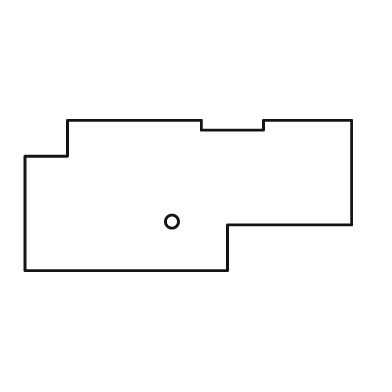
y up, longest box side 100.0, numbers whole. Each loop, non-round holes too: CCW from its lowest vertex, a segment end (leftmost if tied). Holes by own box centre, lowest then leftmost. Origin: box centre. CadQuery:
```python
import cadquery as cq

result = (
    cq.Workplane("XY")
    .moveTo(-50.0, -23.0)
    .lineTo(12.0, -23.0)
    .lineTo(12.0, -9.0)
    .lineTo(50.0, -9.0)
    .lineTo(50.0, 23.0)
    .lineTo(23.0, 23.0)
    .lineTo(23.0, 20.0)
    .lineTo(4.0, 20.0)
    .lineTo(4.0, 23.0)
    .lineTo(-37.0, 23.0)
    .lineTo(-37.0, 12.0)
    .lineTo(-50.0, 12.0)
    .close()
    .moveTo(-5.0, -8.0)
    .circle(2.0)
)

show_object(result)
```